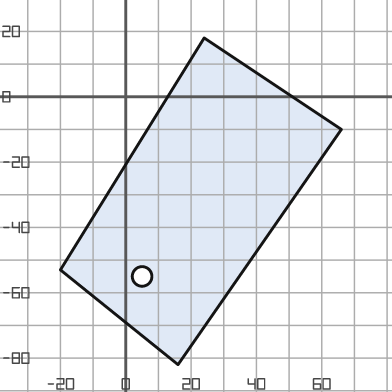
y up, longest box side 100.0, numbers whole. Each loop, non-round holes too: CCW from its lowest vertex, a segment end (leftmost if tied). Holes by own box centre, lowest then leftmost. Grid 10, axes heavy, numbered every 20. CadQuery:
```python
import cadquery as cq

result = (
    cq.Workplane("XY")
    .moveTo(16.0, -82.0)
    .lineTo(66.0, -10.0)
    .lineTo(24.0, 18.0)
    .lineTo(-20.0, -53.0)
    .close()
    .moveTo(5.0, -55.0)
    .circle(3.0)
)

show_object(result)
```